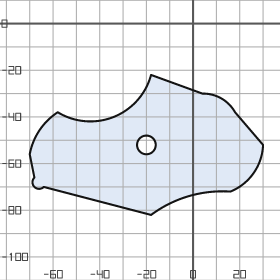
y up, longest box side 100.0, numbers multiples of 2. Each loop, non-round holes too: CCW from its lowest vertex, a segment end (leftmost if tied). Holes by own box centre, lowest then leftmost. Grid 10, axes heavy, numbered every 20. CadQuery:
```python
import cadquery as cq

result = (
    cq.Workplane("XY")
    .moveTo(-18.0, -82.0)
    .threePointArc((-2.0, -74.0), (16.0, -72.0))
    .threePointArc((26.0, -64.0), (30.0, -52.0))
    .lineTo(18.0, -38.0)
    .threePointArc((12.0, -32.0), (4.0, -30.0))
    .lineTo(-18.0, -22.0)
    .threePointArc((-34.0, -40.0), (-58.0, -38.0))
    .threePointArc((-66.0, -46.0), (-70.0, -56.0))
    .lineTo(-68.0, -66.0)
    .threePointArc((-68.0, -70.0), (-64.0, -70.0))
    .close()
    .moveTo(-20.0, -52.0)
    .circle(4.0)
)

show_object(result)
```